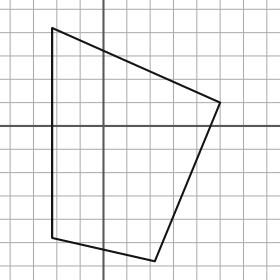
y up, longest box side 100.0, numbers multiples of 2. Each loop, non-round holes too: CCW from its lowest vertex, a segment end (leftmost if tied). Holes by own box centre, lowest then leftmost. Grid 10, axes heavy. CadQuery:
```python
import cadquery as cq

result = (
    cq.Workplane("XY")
    .moveTo(22.0, -58.0)
    .lineTo(50.0, 10.0)
    .lineTo(-22.0, 42.0)
    .lineTo(-22.0, -48.0)
    .close()
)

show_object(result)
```